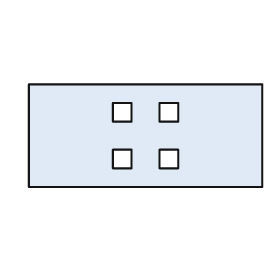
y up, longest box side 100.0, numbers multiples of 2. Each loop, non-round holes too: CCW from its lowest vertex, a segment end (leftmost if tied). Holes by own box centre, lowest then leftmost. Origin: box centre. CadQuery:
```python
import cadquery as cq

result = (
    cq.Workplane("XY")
    .moveTo(-50.0, -22.0)
    .lineTo(50.0, -22.0)
    .lineTo(50.0, 22.0)
    .lineTo(-50.0, 22.0)
    .close()
    .moveTo(-14.0, -14.0)
    .lineTo(-6.0, -14.0)
    .lineTo(-6.0, -6.0)
    .lineTo(-14.0, -6.0)
    .close()
    .moveTo(6.0, -14.0)
    .lineTo(14.0, -14.0)
    .lineTo(14.0, -6.0)
    .lineTo(6.0, -6.0)
    .close()
    .moveTo(-14.0, 6.0)
    .lineTo(-6.0, 6.0)
    .lineTo(-6.0, 14.0)
    .lineTo(-14.0, 14.0)
    .close()
    .moveTo(6.0, 6.0)
    .lineTo(14.0, 6.0)
    .lineTo(14.0, 14.0)
    .lineTo(6.0, 14.0)
    .close()
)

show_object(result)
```